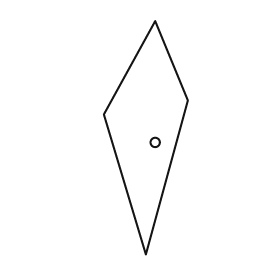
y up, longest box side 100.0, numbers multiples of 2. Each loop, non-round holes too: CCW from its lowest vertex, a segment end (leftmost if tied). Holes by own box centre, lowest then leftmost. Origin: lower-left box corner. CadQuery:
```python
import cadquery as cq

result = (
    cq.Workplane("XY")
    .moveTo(18.0, 0.0)
    .lineTo(36.0, 66.0)
    .lineTo(22.0, 100.0)
    .lineTo(0.0, 60.0)
    .close()
    .moveTo(22.0, 48.0)
    .circle(2.0)
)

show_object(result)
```